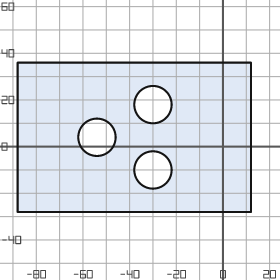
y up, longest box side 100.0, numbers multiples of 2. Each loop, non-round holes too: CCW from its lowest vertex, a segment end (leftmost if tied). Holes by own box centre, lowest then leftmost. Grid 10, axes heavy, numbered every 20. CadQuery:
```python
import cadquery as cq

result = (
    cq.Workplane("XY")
    .moveTo(-88.0, -28.0)
    .lineTo(12.0, -28.0)
    .lineTo(12.0, 36.0)
    .lineTo(-88.0, 36.0)
    .close()
    .moveTo(-30.0, -10.0)
    .circle(8.0)
    .moveTo(-54.0, 4.0)
    .circle(8.0)
    .moveTo(-30.0, 18.0)
    .circle(8.0)
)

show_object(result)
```